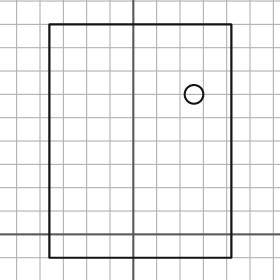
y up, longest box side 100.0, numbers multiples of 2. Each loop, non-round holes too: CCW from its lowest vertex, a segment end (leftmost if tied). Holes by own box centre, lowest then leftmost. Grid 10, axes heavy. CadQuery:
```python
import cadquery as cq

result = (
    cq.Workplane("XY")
    .moveTo(-36.0, -10.0)
    .lineTo(42.0, -10.0)
    .lineTo(42.0, 90.0)
    .lineTo(-36.0, 90.0)
    .close()
    .moveTo(26.0, 60.0)
    .circle(4.0)
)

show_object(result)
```